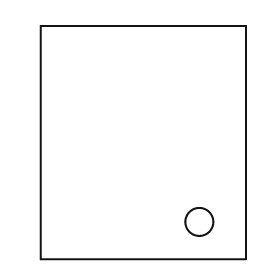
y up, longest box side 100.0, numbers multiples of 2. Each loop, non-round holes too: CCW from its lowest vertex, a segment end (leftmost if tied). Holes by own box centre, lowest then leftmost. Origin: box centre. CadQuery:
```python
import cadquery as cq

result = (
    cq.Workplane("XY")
    .moveTo(-44.0, -50.0)
    .lineTo(44.0, -50.0)
    .lineTo(44.0, 50.0)
    .lineTo(-44.0, 50.0)
    .close()
    .moveTo(24.0, -34.0)
    .circle(6.0)
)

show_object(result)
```